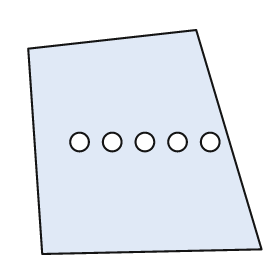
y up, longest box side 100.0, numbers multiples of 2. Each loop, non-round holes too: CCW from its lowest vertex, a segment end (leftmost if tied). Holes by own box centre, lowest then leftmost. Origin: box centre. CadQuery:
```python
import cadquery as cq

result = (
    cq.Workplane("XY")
    .moveTo(-44.0, -48.0)
    .lineTo(50.0, -46.0)
    .lineTo(22.0, 48.0)
    .lineTo(-50.0, 40.0)
    .close()
    .moveTo(-28.0, 0.0)
    .circle(4.0)
    .moveTo(-14.0, 0.0)
    .circle(4.0)
    .moveTo(0.0, 0.0)
    .circle(4.0)
    .moveTo(14.0, 0.0)
    .circle(4.0)
    .moveTo(28.0, 0.0)
    .circle(4.0)
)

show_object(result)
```